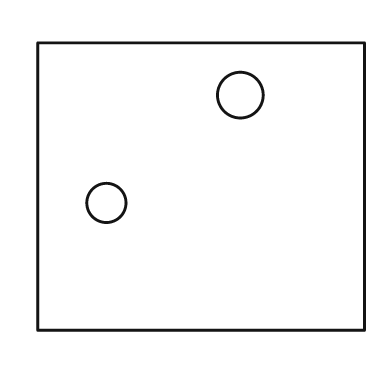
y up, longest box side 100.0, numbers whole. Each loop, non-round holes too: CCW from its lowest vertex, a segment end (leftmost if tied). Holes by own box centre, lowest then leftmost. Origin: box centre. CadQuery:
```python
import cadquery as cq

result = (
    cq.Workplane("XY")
    .moveTo(-50.0, -44.0)
    .lineTo(50.0, -44.0)
    .lineTo(50.0, 44.0)
    .lineTo(-50.0, 44.0)
    .close()
    .moveTo(-29.0, -5.0)
    .circle(6.0)
    .moveTo(12.0, 28.0)
    .circle(7.0)
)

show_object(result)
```